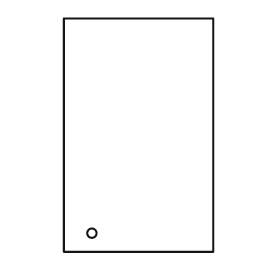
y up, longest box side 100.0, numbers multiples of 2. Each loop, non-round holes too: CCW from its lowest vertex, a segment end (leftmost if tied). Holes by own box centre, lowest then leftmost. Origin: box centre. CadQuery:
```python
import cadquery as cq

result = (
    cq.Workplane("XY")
    .moveTo(-32.0, -50.0)
    .lineTo(32.0, -50.0)
    .lineTo(32.0, 50.0)
    .lineTo(-32.0, 50.0)
    .close()
    .moveTo(-20.0, -42.0)
    .circle(2.0)
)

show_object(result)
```